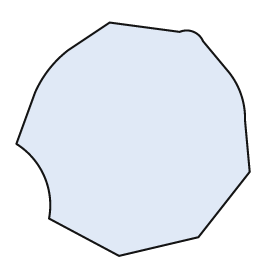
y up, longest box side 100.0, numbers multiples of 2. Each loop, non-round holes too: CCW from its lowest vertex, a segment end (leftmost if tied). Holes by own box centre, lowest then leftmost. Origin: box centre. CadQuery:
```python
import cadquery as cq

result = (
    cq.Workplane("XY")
    .moveTo(-6.0, -50.0)
    .lineTo(28.0, -42.0)
    .lineTo(50.0, -14.0)
    .lineTo(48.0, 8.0)
    .threePointArc((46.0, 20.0), (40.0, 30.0))
    .lineTo(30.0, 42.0)
    .threePointArc((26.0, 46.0), (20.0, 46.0))
    .lineTo(-10.0, 50.0)
    .lineTo(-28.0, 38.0)
    .threePointArc((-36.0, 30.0), (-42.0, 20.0))
    .lineTo(-50.0, -2.0)
    .threePointArc((-38.0, -16.0), (-36.0, -34.0))
    .close()
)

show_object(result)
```